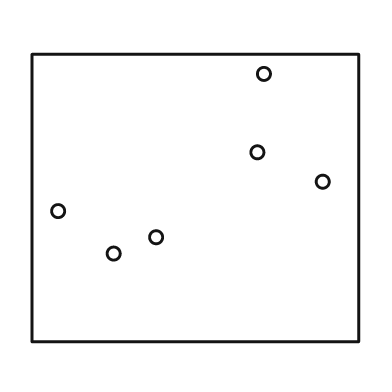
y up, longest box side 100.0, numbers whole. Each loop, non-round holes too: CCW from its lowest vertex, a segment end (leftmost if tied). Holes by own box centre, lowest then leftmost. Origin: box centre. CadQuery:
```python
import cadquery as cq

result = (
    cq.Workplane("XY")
    .moveTo(-50.0, -44.0)
    .lineTo(50.0, -44.0)
    .lineTo(50.0, 44.0)
    .lineTo(-50.0, 44.0)
    .close()
    .moveTo(-25.0, -17.0)
    .circle(2.0)
    .moveTo(-12.0, -12.0)
    .circle(2.0)
    .moveTo(-42.0, -4.0)
    .circle(2.0)
    .moveTo(39.0, 5.0)
    .circle(2.0)
    .moveTo(19.0, 14.0)
    .circle(2.0)
    .moveTo(21.0, 38.0)
    .circle(2.0)
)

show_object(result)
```